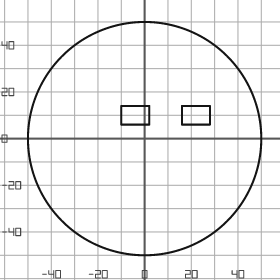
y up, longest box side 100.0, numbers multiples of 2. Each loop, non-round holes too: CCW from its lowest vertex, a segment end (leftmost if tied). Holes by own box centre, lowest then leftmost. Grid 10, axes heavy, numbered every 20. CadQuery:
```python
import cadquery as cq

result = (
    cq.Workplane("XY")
    .moveTo(0.0, 0.0)
    .circle(50.0)
    .moveTo(-10.0, 6.0)
    .lineTo(2.0, 6.0)
    .lineTo(2.0, 14.0)
    .lineTo(-10.0, 14.0)
    .close()
    .moveTo(16.0, 6.0)
    .lineTo(28.0, 6.0)
    .lineTo(28.0, 14.0)
    .lineTo(16.0, 14.0)
    .close()
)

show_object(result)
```